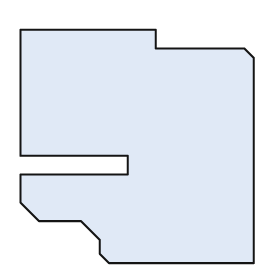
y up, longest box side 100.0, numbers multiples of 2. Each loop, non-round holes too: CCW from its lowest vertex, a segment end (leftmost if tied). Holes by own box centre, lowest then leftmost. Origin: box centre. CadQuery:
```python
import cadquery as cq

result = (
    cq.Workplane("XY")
    .moveTo(-12.0, -50.0)
    .lineTo(50.0, -50.0)
    .lineTo(50.0, 38.0)
    .lineTo(46.0, 42.0)
    .lineTo(8.0, 42.0)
    .lineTo(8.0, 50.0)
    .lineTo(-50.0, 50.0)
    .lineTo(-50.0, -4.0)
    .lineTo(-4.0, -4.0)
    .lineTo(-4.0, -12.0)
    .lineTo(-50.0, -12.0)
    .lineTo(-50.0, -24.0)
    .lineTo(-42.0, -32.0)
    .lineTo(-24.0, -32.0)
    .lineTo(-16.0, -40.0)
    .lineTo(-16.0, -46.0)
    .close()
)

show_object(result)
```